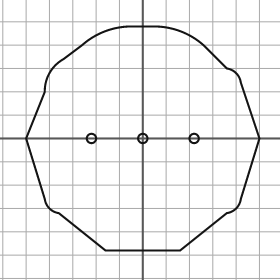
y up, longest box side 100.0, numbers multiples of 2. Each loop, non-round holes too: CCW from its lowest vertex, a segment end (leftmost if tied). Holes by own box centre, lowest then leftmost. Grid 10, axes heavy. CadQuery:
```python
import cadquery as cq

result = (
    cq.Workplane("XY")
    .moveTo(-16.0, -48.0)
    .lineTo(16.0, -48.0)
    .lineTo(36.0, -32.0)
    .threePointArc((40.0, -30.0), (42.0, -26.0))
    .lineTo(50.0, 0.0)
    .lineTo(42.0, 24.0)
    .threePointArc((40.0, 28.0), (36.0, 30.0))
    .lineTo(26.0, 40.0)
    .threePointArc((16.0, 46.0), (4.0, 48.0))
    .lineTo(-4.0, 48.0)
    .threePointArc((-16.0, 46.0), (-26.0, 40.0))
    .lineTo(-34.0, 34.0)
    .threePointArc((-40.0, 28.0), (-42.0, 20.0))
    .lineTo(-50.0, 0.0)
    .lineTo(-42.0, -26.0)
    .threePointArc((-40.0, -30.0), (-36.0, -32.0))
    .close()
    .moveTo(-22.0, 0.0)
    .circle(2.0)
    .moveTo(0.0, 0.0)
    .circle(2.0)
    .moveTo(22.0, 0.0)
    .circle(2.0)
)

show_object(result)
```